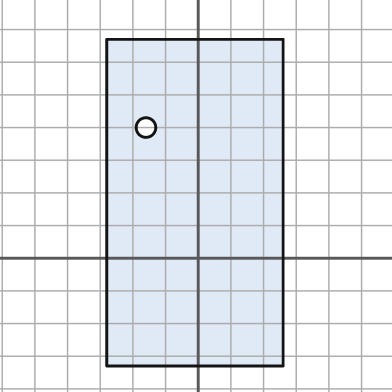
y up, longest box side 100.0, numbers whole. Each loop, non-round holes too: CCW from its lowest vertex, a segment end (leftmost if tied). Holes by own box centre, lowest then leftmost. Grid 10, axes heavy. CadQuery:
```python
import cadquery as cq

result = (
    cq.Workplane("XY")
    .moveTo(-28.0, -33.0)
    .lineTo(26.0, -33.0)
    .lineTo(26.0, 67.0)
    .lineTo(-28.0, 67.0)
    .close()
    .moveTo(-16.0, 40.0)
    .circle(3.0)
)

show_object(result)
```